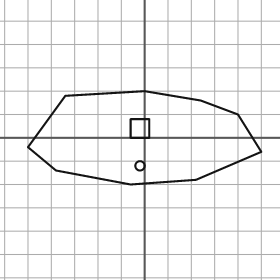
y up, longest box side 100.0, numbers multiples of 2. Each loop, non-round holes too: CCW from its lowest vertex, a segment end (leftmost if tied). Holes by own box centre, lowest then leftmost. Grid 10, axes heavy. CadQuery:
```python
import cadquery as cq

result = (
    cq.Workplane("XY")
    .moveTo(-6.0, -20.0)
    .lineTo(22.0, -18.0)
    .lineTo(50.0, -6.0)
    .lineTo(40.0, 10.0)
    .lineTo(24.0, 16.0)
    .lineTo(0.0, 20.0)
    .lineTo(-34.0, 18.0)
    .lineTo(-50.0, -4.0)
    .lineTo(-38.0, -14.0)
    .close()
    .moveTo(-2.0, -12.0)
    .circle(2.0)
    .moveTo(-6.0, 0.0)
    .lineTo(2.0, 0.0)
    .lineTo(2.0, 8.0)
    .lineTo(-6.0, 8.0)
    .close()
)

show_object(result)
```